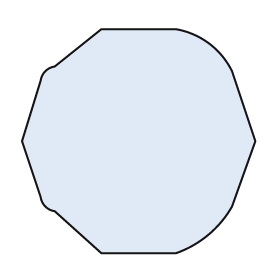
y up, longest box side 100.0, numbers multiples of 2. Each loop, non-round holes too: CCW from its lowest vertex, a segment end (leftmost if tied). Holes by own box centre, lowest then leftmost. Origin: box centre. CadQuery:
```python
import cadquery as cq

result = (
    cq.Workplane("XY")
    .moveTo(-16.0, -48.0)
    .lineTo(16.0, -48.0)
    .threePointArc((30.0, -40.0), (40.0, -28.0))
    .lineTo(50.0, 0.0)
    .lineTo(40.0, 30.0)
    .threePointArc((30.0, 42.0), (16.0, 48.0))
    .lineTo(-16.0, 48.0)
    .lineTo(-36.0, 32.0)
    .threePointArc((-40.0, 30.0), (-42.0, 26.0))
    .lineTo(-50.0, 0.0)
    .lineTo(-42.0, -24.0)
    .threePointArc((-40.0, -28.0), (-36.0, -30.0))
    .close()
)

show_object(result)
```